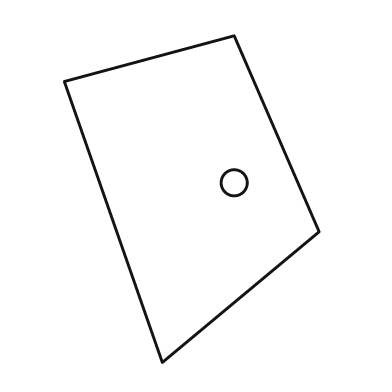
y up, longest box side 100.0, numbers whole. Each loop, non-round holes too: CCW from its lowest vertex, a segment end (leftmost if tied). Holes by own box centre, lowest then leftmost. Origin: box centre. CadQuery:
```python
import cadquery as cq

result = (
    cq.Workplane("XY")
    .moveTo(-9.0, -50.0)
    .lineTo(39.0, -10.0)
    .lineTo(13.0, 50.0)
    .lineTo(-39.0, 36.0)
    .close()
    .moveTo(13.0, 5.0)
    .circle(4.0)
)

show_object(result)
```